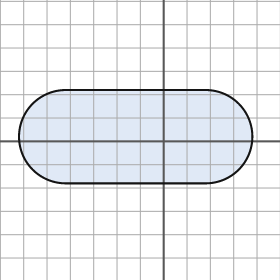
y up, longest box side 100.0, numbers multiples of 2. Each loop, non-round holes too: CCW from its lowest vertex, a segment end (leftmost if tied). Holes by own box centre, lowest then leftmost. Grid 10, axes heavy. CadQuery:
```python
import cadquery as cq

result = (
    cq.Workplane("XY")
    .moveTo(-42.0, -18.0)
    .lineTo(18.0, -18.0)
    .threePointArc((38.0, 2.0), (18.0, 22.0))
    .lineTo(-42.0, 22.0)
    .threePointArc((-62.0, 2.0), (-42.0, -18.0))
    .close()
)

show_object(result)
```